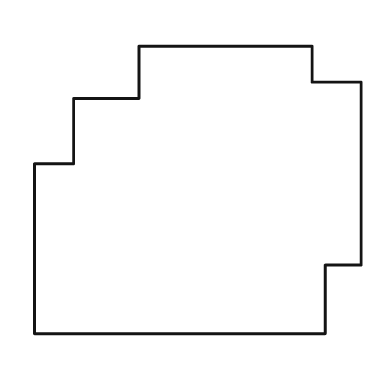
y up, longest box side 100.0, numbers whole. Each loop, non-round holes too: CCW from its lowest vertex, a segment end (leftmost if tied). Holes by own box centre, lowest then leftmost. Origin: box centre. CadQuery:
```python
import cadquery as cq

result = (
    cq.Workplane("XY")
    .moveTo(-50.0, -44.0)
    .lineTo(39.0, -44.0)
    .lineTo(39.0, -23.0)
    .lineTo(50.0, -23.0)
    .lineTo(50.0, 33.0)
    .lineTo(35.0, 33.0)
    .lineTo(35.0, 44.0)
    .lineTo(-18.0, 44.0)
    .lineTo(-18.0, 28.0)
    .lineTo(-38.0, 28.0)
    .lineTo(-38.0, 8.0)
    .lineTo(-50.0, 8.0)
    .close()
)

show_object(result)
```